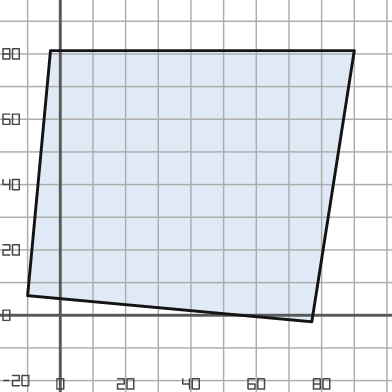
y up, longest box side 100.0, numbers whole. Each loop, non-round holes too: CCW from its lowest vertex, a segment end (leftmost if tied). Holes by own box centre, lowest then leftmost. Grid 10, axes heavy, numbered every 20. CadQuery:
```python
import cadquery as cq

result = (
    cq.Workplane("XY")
    .moveTo(77.0, -2.0)
    .lineTo(90.0, 81.0)
    .lineTo(-3.0, 81.0)
    .lineTo(-10.0, 6.0)
    .close()
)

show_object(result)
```